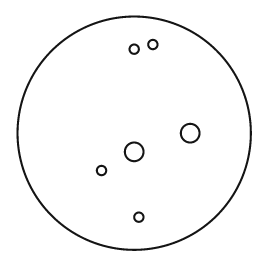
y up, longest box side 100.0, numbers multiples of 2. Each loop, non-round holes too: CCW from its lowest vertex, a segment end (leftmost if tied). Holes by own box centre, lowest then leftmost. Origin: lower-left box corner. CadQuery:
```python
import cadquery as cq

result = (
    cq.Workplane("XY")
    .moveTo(50.0, 50.0)
    .circle(50.0)
    .moveTo(52.0, 14.0)
    .circle(2.0)
    .moveTo(36.0, 34.0)
    .circle(2.0)
    .moveTo(50.0, 42.0)
    .circle(4.0)
    .moveTo(74.0, 50.0)
    .circle(4.0)
    .moveTo(50.0, 86.0)
    .circle(2.0)
    .moveTo(58.0, 88.0)
    .circle(2.0)
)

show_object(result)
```